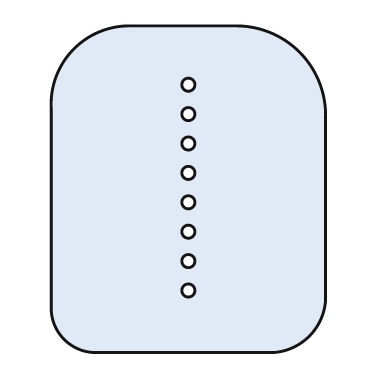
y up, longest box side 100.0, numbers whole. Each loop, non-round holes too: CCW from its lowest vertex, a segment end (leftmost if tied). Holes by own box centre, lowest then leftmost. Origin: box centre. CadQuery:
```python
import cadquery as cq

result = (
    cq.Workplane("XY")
    .moveTo(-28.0, -50.0)
    .lineTo(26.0, -50.0)
    .threePointArc((37.0, -45.0), (42.0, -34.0))
    .lineTo(42.0, 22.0)
    .threePointArc((34.0, 42.0), (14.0, 50.0))
    .lineTo(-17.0, 50.0)
    .threePointArc((-35.0, 43.0), (-42.0, 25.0))
    .lineTo(-42.0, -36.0)
    .threePointArc((-38.0, -46.0), (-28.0, -50.0))
    .close()
    .moveTo(0.0, -31.0)
    .circle(2.0)
    .moveTo(0.0, -22.0)
    .circle(2.0)
    .moveTo(0.0, -13.0)
    .circle(2.0)
    .moveTo(0.0, -4.0)
    .circle(2.0)
    .moveTo(0.0, 5.0)
    .circle(2.0)
    .moveTo(0.0, 14.0)
    .circle(2.0)
    .moveTo(0.0, 23.0)
    .circle(2.0)
    .moveTo(0.0, 32.0)
    .circle(2.0)
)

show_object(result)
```